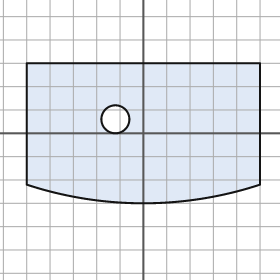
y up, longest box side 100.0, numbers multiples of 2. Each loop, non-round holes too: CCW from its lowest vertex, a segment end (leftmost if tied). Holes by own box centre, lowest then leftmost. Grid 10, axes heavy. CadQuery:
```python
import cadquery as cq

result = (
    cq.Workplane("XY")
    .moveTo(-50.0, -22.0)
    .threePointArc((0.0, -30.0), (50.0, -22.0))
    .lineTo(50.0, 30.0)
    .lineTo(-50.0, 30.0)
    .close()
    .moveTo(-12.0, 6.0)
    .circle(6.0)
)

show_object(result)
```